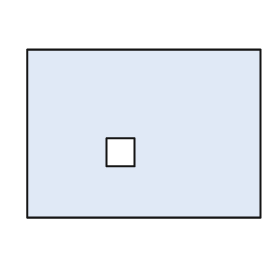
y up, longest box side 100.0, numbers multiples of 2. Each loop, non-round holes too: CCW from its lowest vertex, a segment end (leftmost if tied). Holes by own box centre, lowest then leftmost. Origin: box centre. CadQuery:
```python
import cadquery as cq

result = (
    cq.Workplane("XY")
    .moveTo(-50.0, -36.0)
    .lineTo(50.0, -36.0)
    .lineTo(50.0, 36.0)
    .lineTo(-50.0, 36.0)
    .close()
    .moveTo(-16.0, -14.0)
    .lineTo(-4.0, -14.0)
    .lineTo(-4.0, -2.0)
    .lineTo(-16.0, -2.0)
    .close()
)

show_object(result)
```